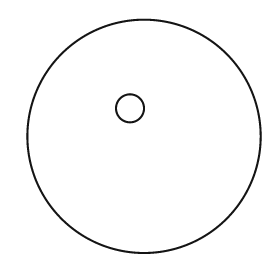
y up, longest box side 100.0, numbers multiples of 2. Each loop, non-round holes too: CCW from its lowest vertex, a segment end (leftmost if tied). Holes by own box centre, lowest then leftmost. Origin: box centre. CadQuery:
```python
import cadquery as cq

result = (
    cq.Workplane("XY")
    .moveTo(0.0, 0.0)
    .circle(50.0)
    .moveTo(-6.0, 12.0)
    .circle(6.0)
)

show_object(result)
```